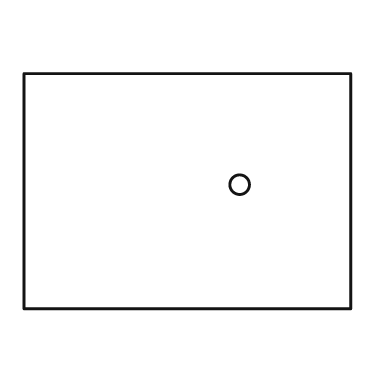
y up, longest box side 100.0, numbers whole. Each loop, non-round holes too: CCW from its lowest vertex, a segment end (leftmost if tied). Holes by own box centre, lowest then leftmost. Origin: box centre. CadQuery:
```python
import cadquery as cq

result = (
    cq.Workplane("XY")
    .moveTo(-50.0, -36.0)
    .lineTo(50.0, -36.0)
    .lineTo(50.0, 36.0)
    .lineTo(-50.0, 36.0)
    .close()
    .moveTo(16.0, 2.0)
    .circle(3.0)
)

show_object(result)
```